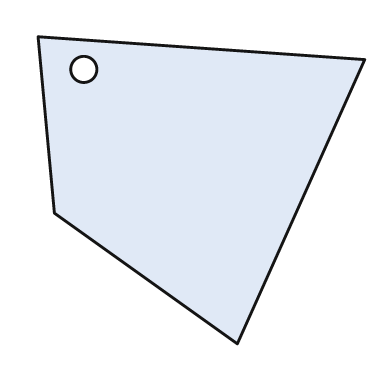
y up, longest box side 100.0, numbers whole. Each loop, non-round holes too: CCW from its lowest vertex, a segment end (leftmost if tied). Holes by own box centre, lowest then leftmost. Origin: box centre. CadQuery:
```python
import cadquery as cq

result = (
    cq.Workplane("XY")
    .moveTo(11.0, -47.0)
    .lineTo(50.0, 40.0)
    .lineTo(-50.0, 47.0)
    .lineTo(-45.0, -7.0)
    .close()
    .moveTo(-36.0, 37.0)
    .circle(4.0)
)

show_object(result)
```